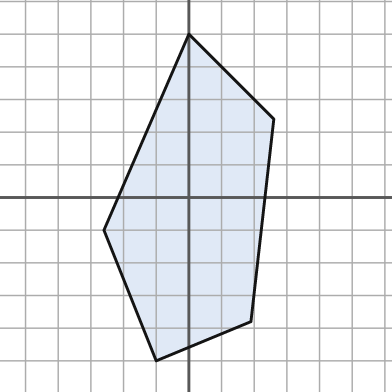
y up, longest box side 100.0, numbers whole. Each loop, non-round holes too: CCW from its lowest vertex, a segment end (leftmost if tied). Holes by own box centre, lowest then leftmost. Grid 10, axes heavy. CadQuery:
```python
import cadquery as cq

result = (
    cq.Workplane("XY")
    .moveTo(-10.0, -50.0)
    .lineTo(19.0, -38.0)
    .lineTo(26.0, 24.0)
    .lineTo(0.0, 50.0)
    .lineTo(-26.0, -10.0)
    .close()
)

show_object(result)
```